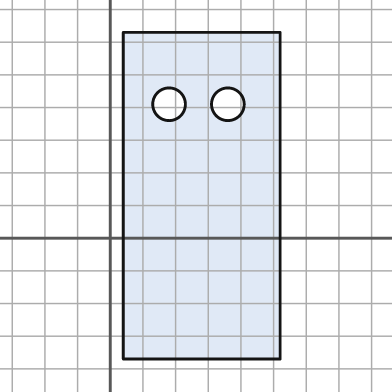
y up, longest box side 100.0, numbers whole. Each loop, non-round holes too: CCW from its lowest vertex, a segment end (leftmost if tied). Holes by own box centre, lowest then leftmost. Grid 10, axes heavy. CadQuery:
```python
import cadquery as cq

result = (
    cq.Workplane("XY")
    .moveTo(4.0, -37.0)
    .lineTo(52.0, -37.0)
    .lineTo(52.0, 63.0)
    .lineTo(4.0, 63.0)
    .close()
    .moveTo(18.0, 41.0)
    .circle(5.0)
    .moveTo(36.0, 41.0)
    .circle(5.0)
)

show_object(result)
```